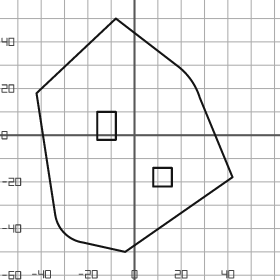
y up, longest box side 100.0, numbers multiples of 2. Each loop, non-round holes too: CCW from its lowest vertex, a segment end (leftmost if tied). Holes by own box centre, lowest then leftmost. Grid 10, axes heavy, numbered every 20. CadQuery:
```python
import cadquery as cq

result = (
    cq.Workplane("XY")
    .moveTo(-4.0, -50.0)
    .lineTo(42.0, -18.0)
    .lineTo(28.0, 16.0)
    .threePointArc((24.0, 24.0), (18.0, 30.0))
    .lineTo(-8.0, 50.0)
    .lineTo(-42.0, 18.0)
    .lineTo(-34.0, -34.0)
    .threePointArc((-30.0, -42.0), (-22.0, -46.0))
    .close()
    .moveTo(8.0, -22.0)
    .lineTo(16.0, -22.0)
    .lineTo(16.0, -14.0)
    .lineTo(8.0, -14.0)
    .close()
    .moveTo(-16.0, -2.0)
    .lineTo(-8.0, -2.0)
    .lineTo(-8.0, 10.0)
    .lineTo(-16.0, 10.0)
    .close()
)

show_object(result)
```